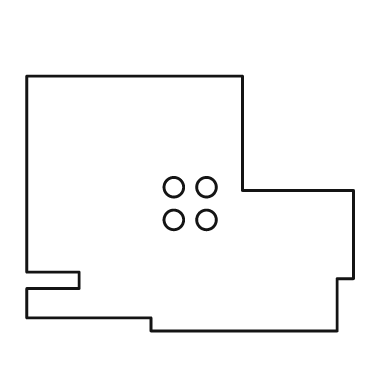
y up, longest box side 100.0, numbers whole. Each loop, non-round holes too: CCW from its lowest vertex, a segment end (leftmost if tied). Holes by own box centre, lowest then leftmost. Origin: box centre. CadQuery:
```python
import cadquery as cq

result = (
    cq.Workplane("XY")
    .moveTo(-12.0, -39.0)
    .lineTo(45.0, -39.0)
    .lineTo(45.0, -23.0)
    .lineTo(50.0, -23.0)
    .lineTo(50.0, 4.0)
    .lineTo(16.0, 4.0)
    .lineTo(16.0, 39.0)
    .lineTo(-50.0, 39.0)
    .lineTo(-50.0, -21.0)
    .lineTo(-34.0, -21.0)
    .lineTo(-34.0, -26.0)
    .lineTo(-50.0, -26.0)
    .lineTo(-50.0, -35.0)
    .lineTo(-12.0, -35.0)
    .close()
    .moveTo(-5.0, -5.0)
    .circle(3.0)
    .moveTo(5.0, -5.0)
    .circle(3.0)
    .moveTo(-5.0, 5.0)
    .circle(3.0)
    .moveTo(5.0, 5.0)
    .circle(3.0)
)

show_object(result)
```